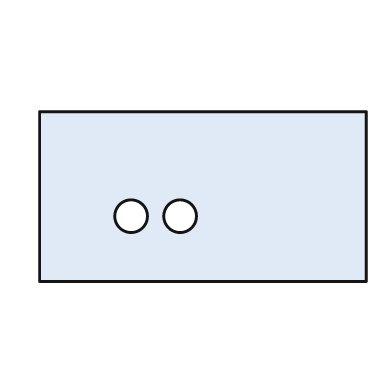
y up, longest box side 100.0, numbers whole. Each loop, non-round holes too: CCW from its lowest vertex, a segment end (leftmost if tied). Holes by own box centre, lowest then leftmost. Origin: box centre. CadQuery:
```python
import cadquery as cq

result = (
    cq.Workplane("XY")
    .moveTo(-50.0, -26.0)
    .lineTo(50.0, -26.0)
    .lineTo(50.0, 26.0)
    .lineTo(-50.0, 26.0)
    .close()
    .moveTo(-22.0, -6.0)
    .circle(5.0)
    .moveTo(-7.0, -6.0)
    .circle(5.0)
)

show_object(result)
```